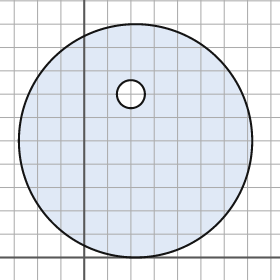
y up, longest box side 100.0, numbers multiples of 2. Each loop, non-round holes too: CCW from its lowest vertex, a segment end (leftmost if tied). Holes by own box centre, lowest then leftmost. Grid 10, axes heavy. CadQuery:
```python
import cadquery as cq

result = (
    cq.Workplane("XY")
    .moveTo(22.0, 50.0)
    .circle(50.0)
    .moveTo(20.0, 70.0)
    .circle(6.0)
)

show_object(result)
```